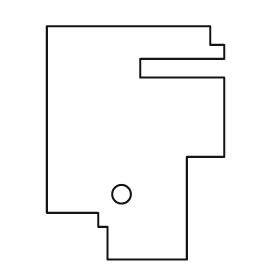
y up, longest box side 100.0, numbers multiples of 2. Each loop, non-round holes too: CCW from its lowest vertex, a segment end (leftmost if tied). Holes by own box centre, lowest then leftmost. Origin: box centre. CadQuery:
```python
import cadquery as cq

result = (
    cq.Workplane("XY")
    .moveTo(-12.0, -50.0)
    .lineTo(22.0, -50.0)
    .lineTo(22.0, -6.0)
    .lineTo(38.0, -6.0)
    .lineTo(38.0, 28.0)
    .lineTo(2.0, 28.0)
    .lineTo(2.0, 36.0)
    .lineTo(38.0, 36.0)
    .lineTo(38.0, 42.0)
    .lineTo(32.0, 42.0)
    .lineTo(32.0, 50.0)
    .lineTo(-38.0, 50.0)
    .lineTo(-38.0, -30.0)
    .lineTo(-16.0, -30.0)
    .lineTo(-16.0, -36.0)
    .lineTo(-12.0, -36.0)
    .close()
    .moveTo(-6.0, -22.0)
    .circle(4.0)
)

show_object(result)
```